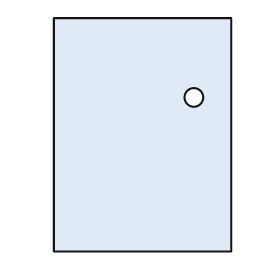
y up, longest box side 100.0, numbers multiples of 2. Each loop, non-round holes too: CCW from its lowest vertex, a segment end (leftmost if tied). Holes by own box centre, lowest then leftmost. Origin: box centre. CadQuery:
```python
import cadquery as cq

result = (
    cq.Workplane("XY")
    .moveTo(-38.0, -50.0)
    .lineTo(38.0, -50.0)
    .lineTo(38.0, 50.0)
    .lineTo(-38.0, 50.0)
    .close()
    .moveTo(22.0, 16.0)
    .circle(4.0)
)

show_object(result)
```